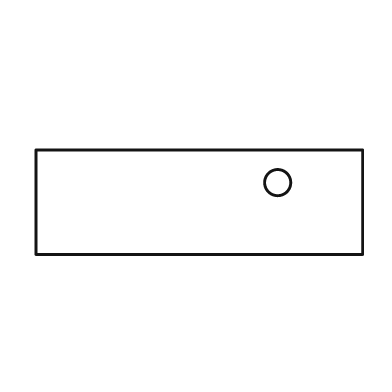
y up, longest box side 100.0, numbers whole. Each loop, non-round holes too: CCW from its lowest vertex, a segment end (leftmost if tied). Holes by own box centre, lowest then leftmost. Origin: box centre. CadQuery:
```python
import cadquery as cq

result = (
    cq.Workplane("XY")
    .moveTo(-50.0, -16.0)
    .lineTo(50.0, -16.0)
    .lineTo(50.0, 16.0)
    .lineTo(-50.0, 16.0)
    .close()
    .moveTo(24.0, 6.0)
    .circle(4.0)
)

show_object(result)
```